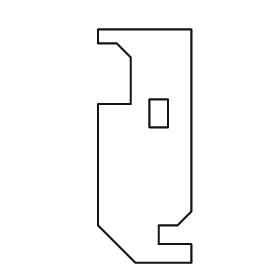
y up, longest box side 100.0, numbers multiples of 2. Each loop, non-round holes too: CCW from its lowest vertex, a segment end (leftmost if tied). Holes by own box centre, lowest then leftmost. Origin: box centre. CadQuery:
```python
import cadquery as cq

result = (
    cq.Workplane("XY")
    .moveTo(-4.0, -50.0)
    .lineTo(20.0, -50.0)
    .lineTo(20.0, -42.0)
    .lineTo(6.0, -42.0)
    .lineTo(6.0, -34.0)
    .lineTo(14.0, -34.0)
    .lineTo(20.0, -28.0)
    .lineTo(20.0, 50.0)
    .lineTo(-20.0, 50.0)
    .lineTo(-20.0, 44.0)
    .lineTo(-12.0, 44.0)
    .lineTo(-6.0, 38.0)
    .lineTo(-6.0, 18.0)
    .lineTo(-20.0, 18.0)
    .lineTo(-20.0, -34.0)
    .close()
    .moveTo(2.0, 8.0)
    .lineTo(10.0, 8.0)
    .lineTo(10.0, 20.0)
    .lineTo(2.0, 20.0)
    .close()
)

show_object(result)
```